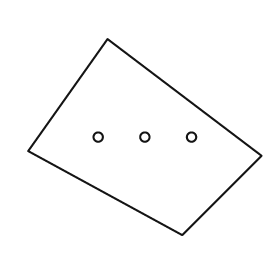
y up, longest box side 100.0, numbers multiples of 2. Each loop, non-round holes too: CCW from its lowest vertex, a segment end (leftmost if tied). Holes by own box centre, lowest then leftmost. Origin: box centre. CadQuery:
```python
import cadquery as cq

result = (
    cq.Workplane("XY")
    .moveTo(16.0, -42.0)
    .lineTo(50.0, -8.0)
    .lineTo(-16.0, 42.0)
    .lineTo(-50.0, -6.0)
    .close()
    .moveTo(-20.0, 0.0)
    .circle(2.0)
    .moveTo(0.0, 0.0)
    .circle(2.0)
    .moveTo(20.0, 0.0)
    .circle(2.0)
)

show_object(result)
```